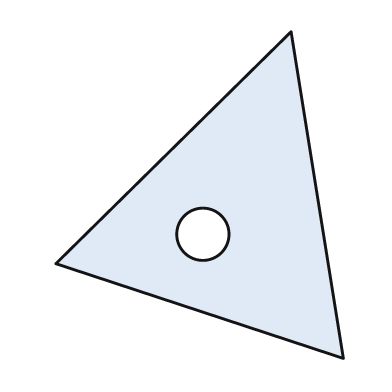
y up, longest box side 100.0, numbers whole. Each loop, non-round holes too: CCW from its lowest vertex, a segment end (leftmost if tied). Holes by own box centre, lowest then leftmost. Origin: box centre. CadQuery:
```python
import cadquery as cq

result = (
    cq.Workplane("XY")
    .moveTo(44.0, -50.0)
    .lineTo(28.0, 50.0)
    .lineTo(-44.0, -21.0)
    .close()
    .moveTo(1.0, -12.0)
    .circle(8.0)
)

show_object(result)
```